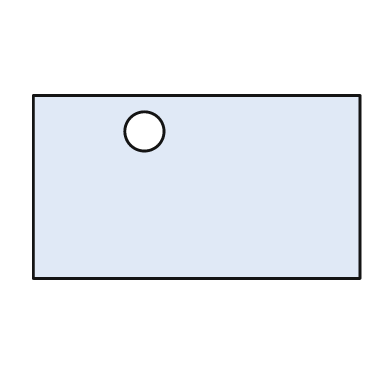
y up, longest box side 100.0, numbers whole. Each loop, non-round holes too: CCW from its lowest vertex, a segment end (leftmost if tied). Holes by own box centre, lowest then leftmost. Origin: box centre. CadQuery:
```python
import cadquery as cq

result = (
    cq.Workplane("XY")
    .moveTo(-50.0, -28.0)
    .lineTo(50.0, -28.0)
    .lineTo(50.0, 28.0)
    .lineTo(-50.0, 28.0)
    .close()
    .moveTo(-16.0, 17.0)
    .circle(6.0)
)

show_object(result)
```